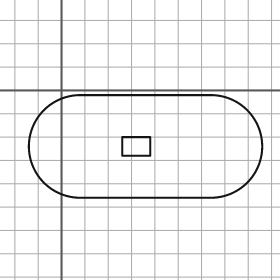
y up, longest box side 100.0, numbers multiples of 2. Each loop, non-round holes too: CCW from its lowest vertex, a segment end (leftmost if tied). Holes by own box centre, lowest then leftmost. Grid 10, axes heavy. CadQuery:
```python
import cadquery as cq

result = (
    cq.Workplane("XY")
    .moveTo(8.0, -46.0)
    .lineTo(64.0, -46.0)
    .threePointArc((86.0, -24.0), (64.0, -2.0))
    .lineTo(8.0, -2.0)
    .threePointArc((-14.0, -24.0), (8.0, -46.0))
    .close()
    .moveTo(26.0, -28.0)
    .lineTo(38.0, -28.0)
    .lineTo(38.0, -20.0)
    .lineTo(26.0, -20.0)
    .close()
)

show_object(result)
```